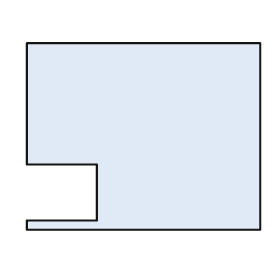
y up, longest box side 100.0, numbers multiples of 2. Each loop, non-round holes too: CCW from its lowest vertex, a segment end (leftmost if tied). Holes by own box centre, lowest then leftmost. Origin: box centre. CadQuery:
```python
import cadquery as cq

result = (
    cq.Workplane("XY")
    .moveTo(-50.0, -40.0)
    .lineTo(50.0, -40.0)
    .lineTo(50.0, 40.0)
    .lineTo(-50.0, 40.0)
    .lineTo(-50.0, -12.0)
    .lineTo(-20.0, -12.0)
    .lineTo(-20.0, -36.0)
    .lineTo(-50.0, -36.0)
    .close()
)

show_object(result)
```